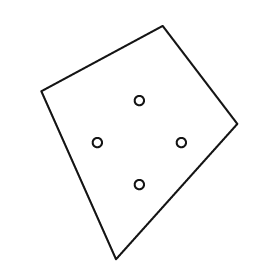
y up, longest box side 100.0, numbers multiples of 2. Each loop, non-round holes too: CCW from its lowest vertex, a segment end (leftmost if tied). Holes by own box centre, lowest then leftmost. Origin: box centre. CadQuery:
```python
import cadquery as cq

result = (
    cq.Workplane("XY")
    .moveTo(-10.0, -50.0)
    .lineTo(42.0, 8.0)
    .lineTo(10.0, 50.0)
    .lineTo(-42.0, 22.0)
    .close()
    .moveTo(0.0, -18.0)
    .circle(2.0)
    .moveTo(-18.0, 0.0)
    .circle(2.0)
    .moveTo(18.0, 0.0)
    .circle(2.0)
    .moveTo(0.0, 18.0)
    .circle(2.0)
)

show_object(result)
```